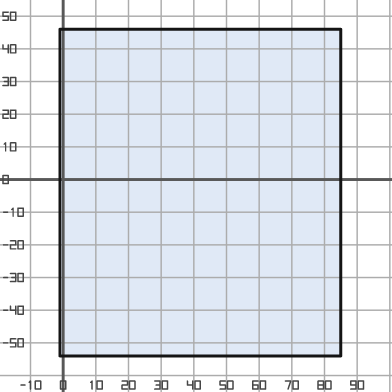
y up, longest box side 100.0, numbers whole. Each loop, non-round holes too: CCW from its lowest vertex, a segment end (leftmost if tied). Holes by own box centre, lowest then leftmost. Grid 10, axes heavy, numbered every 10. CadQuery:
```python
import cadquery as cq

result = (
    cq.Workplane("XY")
    .moveTo(-1.0, -54.0)
    .lineTo(85.0, -54.0)
    .lineTo(85.0, 46.0)
    .lineTo(-1.0, 46.0)
    .close()
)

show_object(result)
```